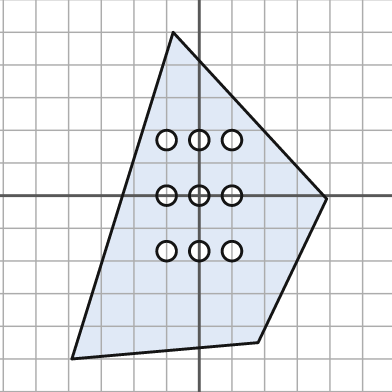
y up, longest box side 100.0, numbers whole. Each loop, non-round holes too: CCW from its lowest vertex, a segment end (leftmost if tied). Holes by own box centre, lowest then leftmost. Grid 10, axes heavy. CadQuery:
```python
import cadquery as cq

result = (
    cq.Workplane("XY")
    .moveTo(-39.0, -50.0)
    .lineTo(18.0, -45.0)
    .lineTo(39.0, -1.0)
    .lineTo(-8.0, 50.0)
    .close()
    .moveTo(-10.0, -17.0)
    .circle(3.0)
    .moveTo(0.0, -17.0)
    .circle(3.0)
    .moveTo(10.0, -17.0)
    .circle(3.0)
    .moveTo(-10.0, 0.0)
    .circle(3.0)
    .moveTo(0.0, 0.0)
    .circle(3.0)
    .moveTo(10.0, 0.0)
    .circle(3.0)
    .moveTo(-10.0, 17.0)
    .circle(3.0)
    .moveTo(0.0, 17.0)
    .circle(3.0)
    .moveTo(10.0, 17.0)
    .circle(3.0)
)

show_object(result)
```